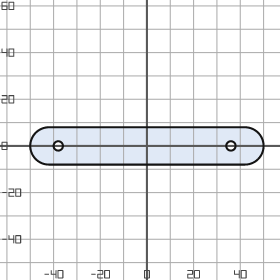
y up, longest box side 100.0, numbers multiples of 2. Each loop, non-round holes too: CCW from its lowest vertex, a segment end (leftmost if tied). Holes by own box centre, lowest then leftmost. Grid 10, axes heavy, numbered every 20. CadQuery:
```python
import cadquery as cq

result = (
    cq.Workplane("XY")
    .moveTo(-42.0, -8.0)
    .lineTo(42.0, -8.0)
    .threePointArc((50.0, 0.0), (42.0, 8.0))
    .lineTo(-42.0, 8.0)
    .threePointArc((-50.0, 0.0), (-42.0, -8.0))
    .close()
    .moveTo(-38.0, 0.0)
    .circle(2.0)
    .moveTo(36.0, 0.0)
    .circle(2.0)
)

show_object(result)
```